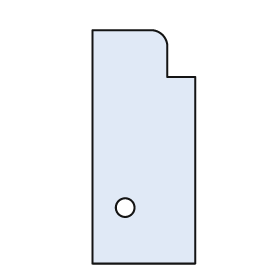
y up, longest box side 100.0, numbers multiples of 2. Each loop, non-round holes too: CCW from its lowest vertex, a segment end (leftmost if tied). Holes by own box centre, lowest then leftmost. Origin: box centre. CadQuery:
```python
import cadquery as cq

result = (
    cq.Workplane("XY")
    .moveTo(-22.0, -50.0)
    .lineTo(22.0, -50.0)
    .lineTo(22.0, 30.0)
    .lineTo(10.0, 30.0)
    .lineTo(10.0, 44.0)
    .threePointArc((8.0, 48.0), (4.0, 50.0))
    .lineTo(-22.0, 50.0)
    .close()
    .moveTo(-8.0, -26.0)
    .circle(4.0)
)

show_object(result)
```